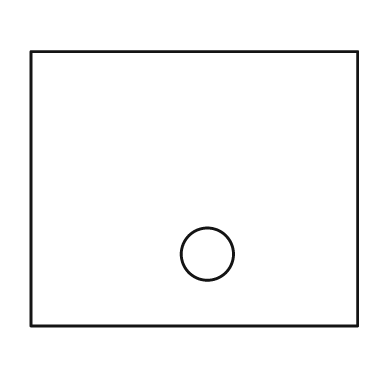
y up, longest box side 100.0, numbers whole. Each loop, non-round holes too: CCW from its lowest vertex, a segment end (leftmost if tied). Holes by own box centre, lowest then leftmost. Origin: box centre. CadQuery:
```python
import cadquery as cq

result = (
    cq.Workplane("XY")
    .moveTo(-50.0, -42.0)
    .lineTo(50.0, -42.0)
    .lineTo(50.0, 42.0)
    .lineTo(-50.0, 42.0)
    .close()
    .moveTo(4.0, -20.0)
    .circle(8.0)
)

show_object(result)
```